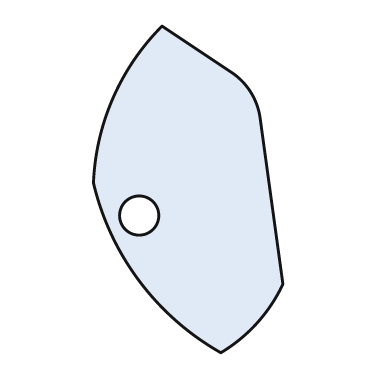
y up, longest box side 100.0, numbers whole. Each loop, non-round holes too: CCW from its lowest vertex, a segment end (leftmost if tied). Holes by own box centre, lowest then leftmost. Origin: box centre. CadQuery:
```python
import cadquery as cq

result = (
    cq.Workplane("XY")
    .moveTo(10.0, -50.0)
    .threePointArc((21.0, -41.0), (29.0, -29.0))
    .lineTo(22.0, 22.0)
    .threePointArc((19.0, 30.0), (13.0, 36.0))
    .lineTo(-8.0, 50.0)
    .threePointArc((-23.0, 28.0), (-29.0, 2.0))
    .threePointArc((-15.0, -28.0), (10.0, -50.0))
    .close()
    .moveTo(-15.0, -8.0)
    .circle(6.0)
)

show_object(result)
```